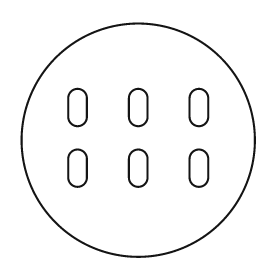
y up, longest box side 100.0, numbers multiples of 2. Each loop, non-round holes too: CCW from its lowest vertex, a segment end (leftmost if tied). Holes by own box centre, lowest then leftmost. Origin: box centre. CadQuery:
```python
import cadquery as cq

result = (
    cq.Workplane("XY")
    .moveTo(0.0, 0.0)
    .circle(50.0)
    .moveTo(-30.0, -16.0)
    .threePointArc((-26.0, -20.0), (-22.0, -16.0))
    .lineTo(-22.0, -8.0)
    .threePointArc((-26.0, -4.0), (-30.0, -8.0))
    .close()
    .moveTo(-4.0, -16.0)
    .threePointArc((0.0, -20.0), (4.0, -16.0))
    .lineTo(4.0, -8.0)
    .threePointArc((0.0, -4.0), (-4.0, -8.0))
    .close()
    .moveTo(22.0, -16.0)
    .threePointArc((26.0, -20.0), (30.0, -16.0))
    .lineTo(30.0, -8.0)
    .threePointArc((26.0, -4.0), (22.0, -8.0))
    .close()
    .moveTo(-30.0, 10.0)
    .threePointArc((-26.0, 6.0), (-22.0, 10.0))
    .lineTo(-22.0, 18.0)
    .threePointArc((-26.0, 22.0), (-30.0, 18.0))
    .close()
    .moveTo(-4.0, 10.0)
    .threePointArc((0.0, 6.0), (4.0, 10.0))
    .lineTo(4.0, 18.0)
    .threePointArc((0.0, 22.0), (-4.0, 18.0))
    .close()
    .moveTo(22.0, 10.0)
    .threePointArc((26.0, 6.0), (30.0, 10.0))
    .lineTo(30.0, 18.0)
    .threePointArc((26.0, 22.0), (22.0, 18.0))
    .close()
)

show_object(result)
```